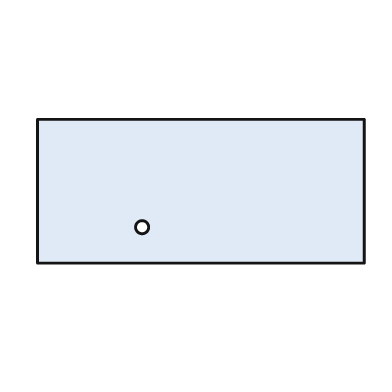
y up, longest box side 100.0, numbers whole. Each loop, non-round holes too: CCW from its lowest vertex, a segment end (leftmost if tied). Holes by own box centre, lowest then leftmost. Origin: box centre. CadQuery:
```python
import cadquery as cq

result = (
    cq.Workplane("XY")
    .moveTo(-50.0, -22.0)
    .lineTo(50.0, -22.0)
    .lineTo(50.0, 22.0)
    .lineTo(-50.0, 22.0)
    .close()
    .moveTo(-18.0, -11.0)
    .circle(2.0)
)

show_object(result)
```